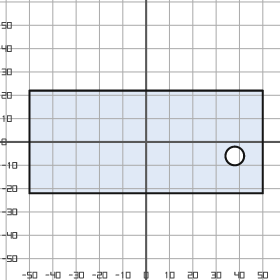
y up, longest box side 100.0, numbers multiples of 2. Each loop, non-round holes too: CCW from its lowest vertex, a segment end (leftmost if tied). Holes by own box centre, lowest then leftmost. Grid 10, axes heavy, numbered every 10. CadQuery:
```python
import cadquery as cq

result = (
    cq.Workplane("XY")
    .moveTo(-50.0, -22.0)
    .lineTo(50.0, -22.0)
    .lineTo(50.0, 22.0)
    .lineTo(-50.0, 22.0)
    .close()
    .moveTo(38.0, -6.0)
    .circle(4.0)
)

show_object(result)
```